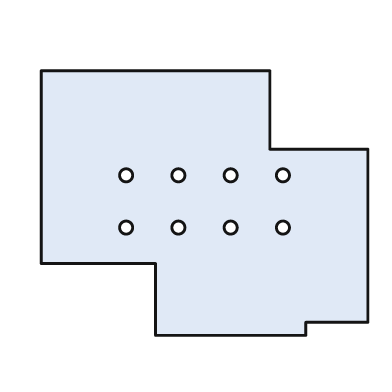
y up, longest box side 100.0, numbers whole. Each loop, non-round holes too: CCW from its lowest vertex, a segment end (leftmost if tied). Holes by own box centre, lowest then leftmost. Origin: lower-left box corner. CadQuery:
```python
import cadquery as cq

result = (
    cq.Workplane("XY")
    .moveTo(35.0, 0.0)
    .lineTo(81.0, 0.0)
    .lineTo(81.0, 4.0)
    .lineTo(100.0, 4.0)
    .lineTo(100.0, 57.0)
    .lineTo(70.0, 57.0)
    .lineTo(70.0, 81.0)
    .lineTo(0.0, 81.0)
    .lineTo(0.0, 22.0)
    .lineTo(35.0, 22.0)
    .close()
    .moveTo(26.0, 33.0)
    .circle(2.0)
    .moveTo(42.0, 33.0)
    .circle(2.0)
    .moveTo(58.0, 33.0)
    .circle(2.0)
    .moveTo(74.0, 33.0)
    .circle(2.0)
    .moveTo(26.0, 49.0)
    .circle(2.0)
    .moveTo(42.0, 49.0)
    .circle(2.0)
    .moveTo(58.0, 49.0)
    .circle(2.0)
    .moveTo(74.0, 49.0)
    .circle(2.0)
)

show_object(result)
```